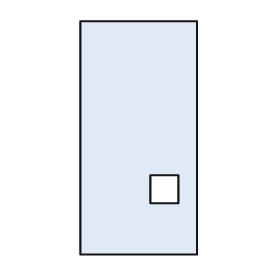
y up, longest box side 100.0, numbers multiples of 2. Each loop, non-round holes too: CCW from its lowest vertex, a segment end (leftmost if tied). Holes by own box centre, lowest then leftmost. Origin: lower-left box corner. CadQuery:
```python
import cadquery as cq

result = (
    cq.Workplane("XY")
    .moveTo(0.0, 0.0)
    .lineTo(50.0, 0.0)
    .lineTo(50.0, 100.0)
    .lineTo(0.0, 100.0)
    .close()
    .moveTo(30.0, 22.0)
    .lineTo(42.0, 22.0)
    .lineTo(42.0, 34.0)
    .lineTo(30.0, 34.0)
    .close()
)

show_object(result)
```